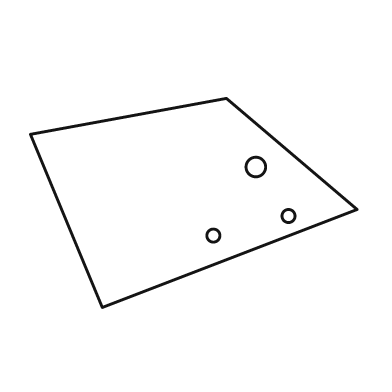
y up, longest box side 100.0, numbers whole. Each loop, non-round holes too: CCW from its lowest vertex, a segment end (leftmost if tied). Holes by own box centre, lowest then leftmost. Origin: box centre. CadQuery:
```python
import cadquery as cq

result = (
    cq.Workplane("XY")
    .moveTo(-28.0, -32.0)
    .lineTo(50.0, -2.0)
    .lineTo(10.0, 32.0)
    .lineTo(-50.0, 21.0)
    .close()
    .moveTo(6.0, -10.0)
    .circle(2.0)
    .moveTo(29.0, -4.0)
    .circle(2.0)
    .moveTo(19.0, 11.0)
    .circle(3.0)
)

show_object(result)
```